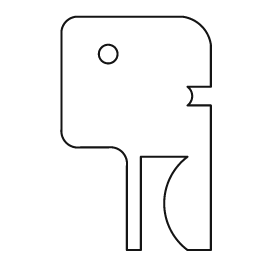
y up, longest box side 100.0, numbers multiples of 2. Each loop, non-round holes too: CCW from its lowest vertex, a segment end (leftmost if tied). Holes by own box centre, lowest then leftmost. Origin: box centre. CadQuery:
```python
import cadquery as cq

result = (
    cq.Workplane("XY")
    .moveTo(-4.0, -50.0)
    .lineTo(2.0, -50.0)
    .lineTo(2.0, -10.0)
    .lineTo(22.0, -10.0)
    .threePointArc((12.0, -30.0), (22.0, -50.0))
    .lineTo(32.0, -50.0)
    .lineTo(32.0, 12.0)
    .lineTo(22.0, 12.0)
    .threePointArc((24.0, 16.0), (22.0, 20.0))
    .lineTo(32.0, 20.0)
    .lineTo(32.0, 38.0)
    .threePointArc((28.0, 46.0), (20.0, 50.0))
    .lineTo(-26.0, 50.0)
    .threePointArc((-30.0, 48.0), (-32.0, 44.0))
    .lineTo(-32.0, 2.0)
    .threePointArc((-30.0, -4.0), (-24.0, -6.0))
    .lineTo(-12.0, -6.0)
    .threePointArc((-6.0, -8.0), (-4.0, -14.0))
    .close()
    .moveTo(-12.0, 34.0)
    .circle(4.0)
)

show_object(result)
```